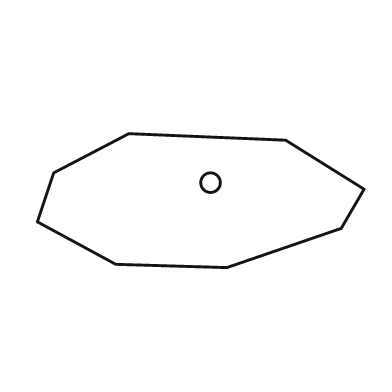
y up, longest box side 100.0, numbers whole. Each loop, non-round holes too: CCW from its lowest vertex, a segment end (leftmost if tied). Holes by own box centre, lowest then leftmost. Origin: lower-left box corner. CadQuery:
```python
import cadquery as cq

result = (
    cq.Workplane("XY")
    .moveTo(58.0, 0.0)
    .lineTo(93.0, 12.0)
    .lineTo(100.0, 24.0)
    .lineTo(76.0, 39.0)
    .lineTo(28.0, 41.0)
    .lineTo(5.0, 29.0)
    .lineTo(0.0, 14.0)
    .lineTo(24.0, 1.0)
    .close()
    .moveTo(53.0, 26.0)
    .circle(3.0)
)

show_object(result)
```